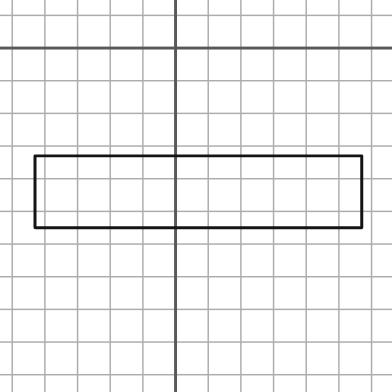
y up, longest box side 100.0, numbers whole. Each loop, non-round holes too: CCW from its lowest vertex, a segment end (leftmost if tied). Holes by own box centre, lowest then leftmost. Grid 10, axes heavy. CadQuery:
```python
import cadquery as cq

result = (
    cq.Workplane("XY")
    .moveTo(-43.0, -55.0)
    .lineTo(57.0, -55.0)
    .lineTo(57.0, -33.0)
    .lineTo(-43.0, -33.0)
    .close()
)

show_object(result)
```